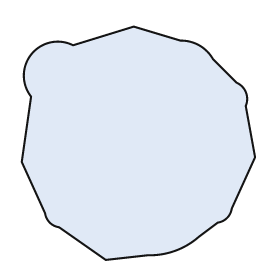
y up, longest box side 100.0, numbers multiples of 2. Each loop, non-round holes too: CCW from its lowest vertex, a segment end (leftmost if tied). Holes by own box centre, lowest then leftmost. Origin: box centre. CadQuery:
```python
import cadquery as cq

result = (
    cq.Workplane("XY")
    .moveTo(-14.0, -50.0)
    .lineTo(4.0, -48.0)
    .threePointArc((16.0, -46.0), (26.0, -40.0))
    .lineTo(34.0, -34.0)
    .threePointArc((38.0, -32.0), (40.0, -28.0))
    .lineTo(50.0, -6.0)
    .lineTo(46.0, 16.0)
    .threePointArc((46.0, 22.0), (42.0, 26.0))
    .lineTo(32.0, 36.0)
    .threePointArc((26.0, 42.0), (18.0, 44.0))
    .lineTo(-2.0, 50.0)
    .lineTo(-28.0, 42.0)
    .threePointArc((-46.0, 38.0), (-46.0, 20.0))
    .lineTo(-50.0, -8.0)
    .lineTo(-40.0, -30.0)
    .threePointArc((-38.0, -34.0), (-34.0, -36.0))
    .close()
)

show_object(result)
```